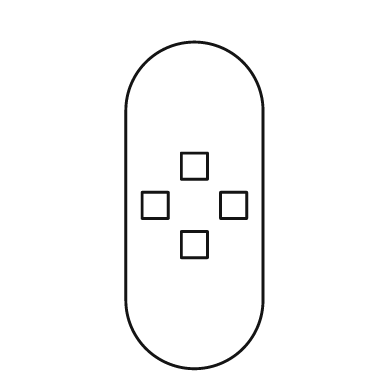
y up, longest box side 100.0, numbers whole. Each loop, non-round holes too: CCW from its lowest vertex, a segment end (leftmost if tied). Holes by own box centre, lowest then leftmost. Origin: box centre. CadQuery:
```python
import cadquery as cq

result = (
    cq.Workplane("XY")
    .moveTo(-21.0, -29.0)
    .threePointArc((0.0, -50.0), (21.0, -29.0))
    .lineTo(21.0, 29.0)
    .threePointArc((0.0, 50.0), (-21.0, 29.0))
    .close()
    .moveTo(-4.0, -16.0)
    .lineTo(4.0, -16.0)
    .lineTo(4.0, -8.0)
    .lineTo(-4.0, -8.0)
    .close()
    .moveTo(-16.0, -4.0)
    .lineTo(-8.0, -4.0)
    .lineTo(-8.0, 4.0)
    .lineTo(-16.0, 4.0)
    .close()
    .moveTo(8.0, -4.0)
    .lineTo(16.0, -4.0)
    .lineTo(16.0, 4.0)
    .lineTo(8.0, 4.0)
    .close()
    .moveTo(-4.0, 8.0)
    .lineTo(4.0, 8.0)
    .lineTo(4.0, 16.0)
    .lineTo(-4.0, 16.0)
    .close()
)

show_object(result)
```